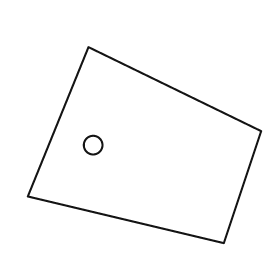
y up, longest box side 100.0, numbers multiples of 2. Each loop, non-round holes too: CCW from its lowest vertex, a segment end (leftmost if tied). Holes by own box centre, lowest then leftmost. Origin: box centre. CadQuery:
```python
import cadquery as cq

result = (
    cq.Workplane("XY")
    .moveTo(34.0, -42.0)
    .lineTo(50.0, 6.0)
    .lineTo(-24.0, 42.0)
    .lineTo(-50.0, -22.0)
    .close()
    .moveTo(-22.0, 0.0)
    .circle(4.0)
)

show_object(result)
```